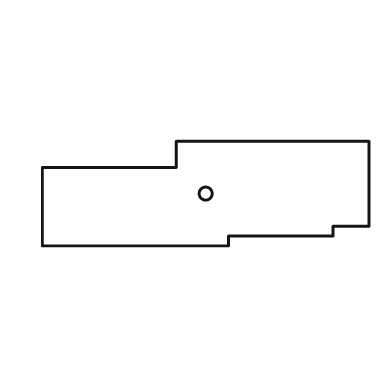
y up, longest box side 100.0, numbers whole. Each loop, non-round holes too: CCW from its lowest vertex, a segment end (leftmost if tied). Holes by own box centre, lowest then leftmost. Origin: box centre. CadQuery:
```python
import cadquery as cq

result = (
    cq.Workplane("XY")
    .moveTo(-50.0, -16.0)
    .lineTo(7.0, -16.0)
    .lineTo(7.0, -13.0)
    .lineTo(39.0, -13.0)
    .lineTo(39.0, -10.0)
    .lineTo(50.0, -10.0)
    .lineTo(50.0, 16.0)
    .lineTo(-9.0, 16.0)
    .lineTo(-9.0, 8.0)
    .lineTo(-50.0, 8.0)
    .close()
    .moveTo(0.0, 0.0)
    .circle(2.0)
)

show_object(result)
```